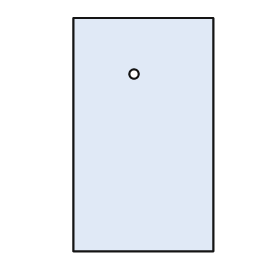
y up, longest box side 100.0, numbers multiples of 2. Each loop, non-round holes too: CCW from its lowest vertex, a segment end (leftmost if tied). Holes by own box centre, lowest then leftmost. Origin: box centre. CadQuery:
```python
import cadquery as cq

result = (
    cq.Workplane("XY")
    .moveTo(-30.0, -50.0)
    .lineTo(30.0, -50.0)
    .lineTo(30.0, 50.0)
    .lineTo(-30.0, 50.0)
    .close()
    .moveTo(-4.0, 26.0)
    .circle(2.0)
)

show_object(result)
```